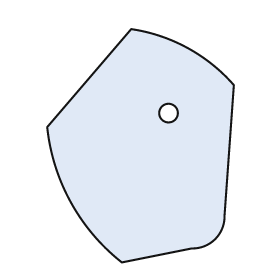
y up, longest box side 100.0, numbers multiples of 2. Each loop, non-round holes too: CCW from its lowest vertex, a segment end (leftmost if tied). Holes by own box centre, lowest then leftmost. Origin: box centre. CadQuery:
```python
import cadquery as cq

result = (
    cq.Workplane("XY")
    .moveTo(-8.0, -50.0)
    .lineTo(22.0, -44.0)
    .threePointArc((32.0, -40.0), (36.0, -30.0))
    .lineTo(40.0, 26.0)
    .threePointArc((20.0, 42.0), (-4.0, 50.0))
    .lineTo(-40.0, 8.0)
    .threePointArc((-30.0, -24.0), (-8.0, -50.0))
    .close()
    .moveTo(12.0, 14.0)
    .circle(4.0)
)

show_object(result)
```